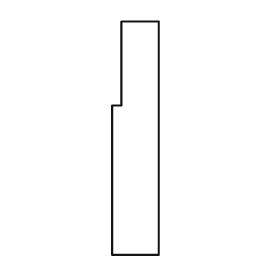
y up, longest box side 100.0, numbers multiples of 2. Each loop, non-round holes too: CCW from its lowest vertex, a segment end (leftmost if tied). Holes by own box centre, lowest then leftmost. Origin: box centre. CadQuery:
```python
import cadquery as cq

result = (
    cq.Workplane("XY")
    .moveTo(-10.0, -50.0)
    .lineTo(10.0, -50.0)
    .lineTo(10.0, 50.0)
    .lineTo(-6.0, 50.0)
    .lineTo(-6.0, 14.0)
    .lineTo(-10.0, 14.0)
    .close()
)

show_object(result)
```